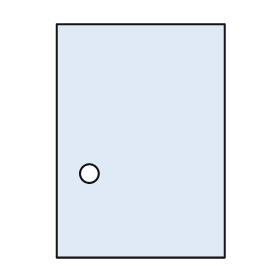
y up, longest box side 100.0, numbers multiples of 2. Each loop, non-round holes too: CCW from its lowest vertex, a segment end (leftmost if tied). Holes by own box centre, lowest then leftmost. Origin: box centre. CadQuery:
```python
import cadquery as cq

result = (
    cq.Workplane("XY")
    .moveTo(-36.0, -50.0)
    .lineTo(36.0, -50.0)
    .lineTo(36.0, 50.0)
    .lineTo(-36.0, 50.0)
    .close()
    .moveTo(-22.0, -14.0)
    .circle(4.0)
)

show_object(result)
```